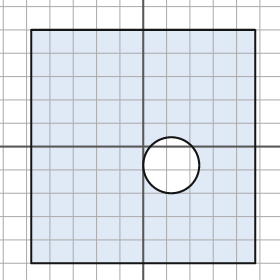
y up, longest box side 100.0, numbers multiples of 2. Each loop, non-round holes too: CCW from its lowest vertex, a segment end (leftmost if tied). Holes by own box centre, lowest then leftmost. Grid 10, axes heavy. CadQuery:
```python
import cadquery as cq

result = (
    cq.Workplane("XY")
    .moveTo(-48.0, -50.0)
    .lineTo(48.0, -50.0)
    .lineTo(48.0, 50.0)
    .lineTo(-48.0, 50.0)
    .close()
    .moveTo(12.0, -8.0)
    .circle(12.0)
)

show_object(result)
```